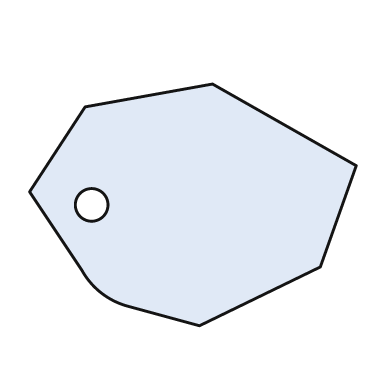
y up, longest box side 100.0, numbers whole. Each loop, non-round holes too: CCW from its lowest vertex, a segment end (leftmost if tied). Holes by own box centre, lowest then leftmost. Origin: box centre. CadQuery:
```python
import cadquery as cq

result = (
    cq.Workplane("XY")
    .moveTo(2.0, -37.0)
    .lineTo(39.0, -19.0)
    .lineTo(50.0, 12.0)
    .lineTo(6.0, 37.0)
    .lineTo(-33.0, 30.0)
    .lineTo(-50.0, 4.0)
    .lineTo(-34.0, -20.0)
    .threePointArc((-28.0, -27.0), (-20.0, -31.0))
    .close()
    .moveTo(-31.0, 0.0)
    .circle(5.0)
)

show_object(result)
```